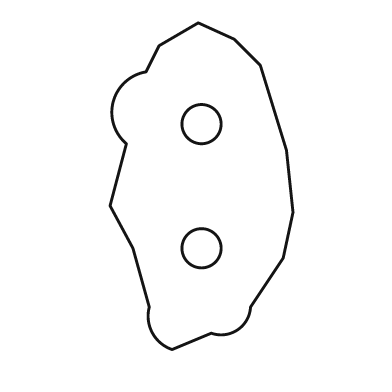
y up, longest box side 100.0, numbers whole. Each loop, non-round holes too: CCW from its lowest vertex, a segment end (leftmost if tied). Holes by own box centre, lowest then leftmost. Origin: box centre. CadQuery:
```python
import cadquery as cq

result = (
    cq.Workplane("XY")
    .moveTo(-9.0, -50.0)
    .lineTo(3.0, -45.0)
    .threePointArc((11.0, -44.0), (15.0, -37.0))
    .lineTo(25.0, -22.0)
    .lineTo(28.0, -8.0)
    .lineTo(26.0, 11.0)
    .lineTo(18.0, 37.0)
    .lineTo(10.0, 45.0)
    .lineTo(-1.0, 50.0)
    .lineTo(-13.0, 43.0)
    .lineTo(-17.0, 35.0)
    .threePointArc((-27.0, 26.0), (-23.0, 13.0))
    .lineTo(-28.0, -6.0)
    .lineTo(-21.0, -19.0)
    .lineTo(-16.0, -37.0)
    .threePointArc((-15.0, -45.0), (-9.0, -50.0))
    .close()
    .moveTo(0.0, -19.0)
    .circle(6.0)
    .moveTo(0.0, 19.0)
    .circle(6.0)
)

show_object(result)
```